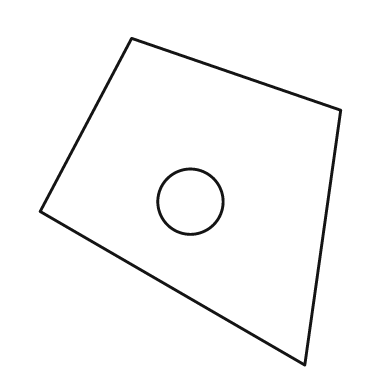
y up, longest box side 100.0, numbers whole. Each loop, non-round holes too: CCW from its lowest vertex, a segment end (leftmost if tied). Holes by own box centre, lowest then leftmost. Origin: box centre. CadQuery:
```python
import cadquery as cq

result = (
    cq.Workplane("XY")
    .moveTo(35.0, -50.0)
    .lineTo(46.0, 28.0)
    .lineTo(-18.0, 50.0)
    .lineTo(-46.0, -3.0)
    .close()
    .moveTo(0.0, 0.0)
    .circle(10.0)
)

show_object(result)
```